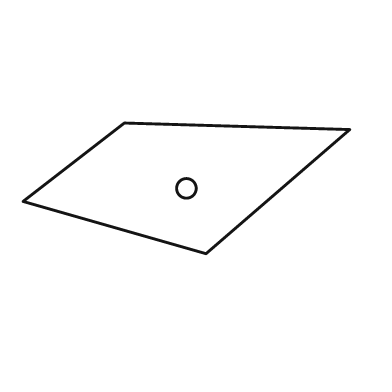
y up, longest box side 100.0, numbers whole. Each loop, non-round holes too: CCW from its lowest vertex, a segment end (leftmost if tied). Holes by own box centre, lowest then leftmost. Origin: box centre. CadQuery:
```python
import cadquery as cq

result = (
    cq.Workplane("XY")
    .moveTo(6.0, -20.0)
    .lineTo(50.0, 18.0)
    .lineTo(-19.0, 20.0)
    .lineTo(-50.0, -4.0)
    .close()
    .moveTo(0.0, 0.0)
    .circle(3.0)
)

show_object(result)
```